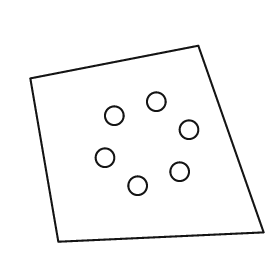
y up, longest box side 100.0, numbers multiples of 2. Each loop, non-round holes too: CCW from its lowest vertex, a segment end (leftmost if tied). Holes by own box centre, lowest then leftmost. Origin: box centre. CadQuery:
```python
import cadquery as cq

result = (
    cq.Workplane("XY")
    .moveTo(-38.0, -42.0)
    .lineTo(50.0, -38.0)
    .lineTo(22.0, 42.0)
    .lineTo(-50.0, 28.0)
    .close()
    .moveTo(-4.0, -18.0)
    .circle(4.0)
    .moveTo(14.0, -12.0)
    .circle(4.0)
    .moveTo(-18.0, -6.0)
    .circle(4.0)
    .moveTo(18.0, 6.0)
    .circle(4.0)
    .moveTo(-14.0, 12.0)
    .circle(4.0)
    .moveTo(4.0, 18.0)
    .circle(4.0)
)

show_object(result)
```